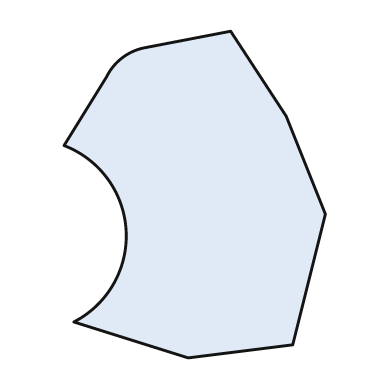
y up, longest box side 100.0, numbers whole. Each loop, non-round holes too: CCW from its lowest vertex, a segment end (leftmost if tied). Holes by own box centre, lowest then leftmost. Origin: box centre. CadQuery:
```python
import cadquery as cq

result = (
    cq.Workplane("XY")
    .moveTo(-2.0, -50.0)
    .lineTo(30.0, -46.0)
    .lineTo(40.0, -6.0)
    .lineTo(28.0, 24.0)
    .lineTo(11.0, 50.0)
    .lineTo(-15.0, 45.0)
    .threePointArc((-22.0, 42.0), (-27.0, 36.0))
    .lineTo(-40.0, 15.0)
    .threePointArc((-21.0, -11.0), (-37.0, -39.0))
    .close()
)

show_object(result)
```